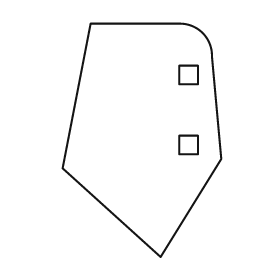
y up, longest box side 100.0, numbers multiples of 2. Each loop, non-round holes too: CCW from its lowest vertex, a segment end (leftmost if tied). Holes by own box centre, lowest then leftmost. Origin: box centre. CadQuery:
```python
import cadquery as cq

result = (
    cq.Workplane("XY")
    .moveTo(8.0, -50.0)
    .lineTo(34.0, -8.0)
    .lineTo(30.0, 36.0)
    .threePointArc((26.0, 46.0), (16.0, 50.0))
    .lineTo(-22.0, 50.0)
    .lineTo(-34.0, -12.0)
    .close()
    .moveTo(16.0, -6.0)
    .lineTo(24.0, -6.0)
    .lineTo(24.0, 2.0)
    .lineTo(16.0, 2.0)
    .close()
    .moveTo(16.0, 24.0)
    .lineTo(24.0, 24.0)
    .lineTo(24.0, 32.0)
    .lineTo(16.0, 32.0)
    .close()
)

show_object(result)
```